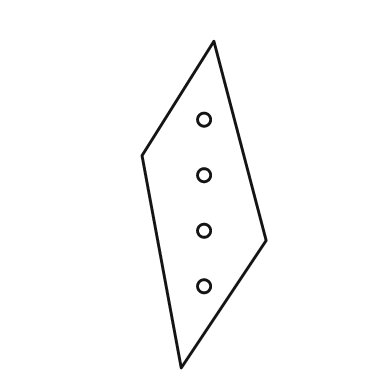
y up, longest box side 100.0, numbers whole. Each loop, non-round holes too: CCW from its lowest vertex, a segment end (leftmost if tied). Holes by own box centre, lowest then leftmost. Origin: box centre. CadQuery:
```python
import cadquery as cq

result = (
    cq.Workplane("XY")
    .moveTo(-7.0, -50.0)
    .lineTo(19.0, -11.0)
    .lineTo(3.0, 50.0)
    .lineTo(-19.0, 15.0)
    .close()
    .moveTo(0.0, -25.0)
    .circle(2.0)
    .moveTo(0.0, -8.0)
    .circle(2.0)
    .moveTo(0.0, 9.0)
    .circle(2.0)
    .moveTo(0.0, 26.0)
    .circle(2.0)
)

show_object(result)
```